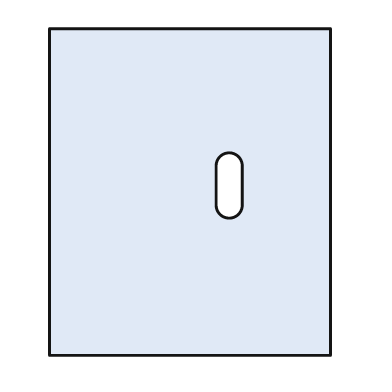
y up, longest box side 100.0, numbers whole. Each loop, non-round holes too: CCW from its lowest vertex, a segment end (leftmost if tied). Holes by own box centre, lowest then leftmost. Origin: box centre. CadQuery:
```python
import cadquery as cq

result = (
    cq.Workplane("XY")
    .moveTo(-43.0, -50.0)
    .lineTo(43.0, -50.0)
    .lineTo(43.0, 50.0)
    .lineTo(-43.0, 50.0)
    .close()
    .moveTo(8.0, -4.0)
    .threePointArc((12.0, -8.0), (16.0, -4.0))
    .lineTo(16.0, 8.0)
    .threePointArc((12.0, 12.0), (8.0, 8.0))
    .close()
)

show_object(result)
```